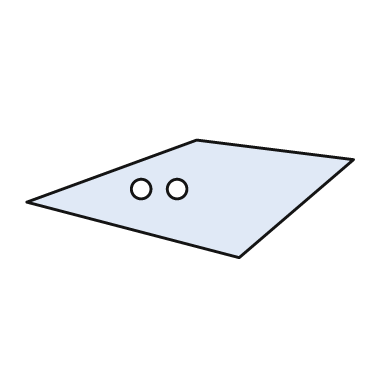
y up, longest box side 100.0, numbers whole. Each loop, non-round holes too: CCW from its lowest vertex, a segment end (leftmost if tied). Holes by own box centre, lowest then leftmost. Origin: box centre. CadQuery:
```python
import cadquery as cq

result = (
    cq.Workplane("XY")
    .moveTo(15.0, -18.0)
    .lineTo(50.0, 12.0)
    .lineTo(2.0, 18.0)
    .lineTo(-50.0, -1.0)
    .close()
    .moveTo(-15.0, 3.0)
    .circle(3.0)
    .moveTo(-4.0, 3.0)
    .circle(3.0)
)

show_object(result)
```